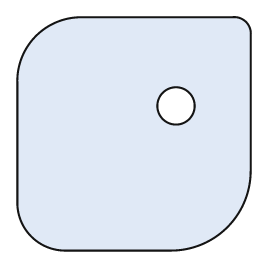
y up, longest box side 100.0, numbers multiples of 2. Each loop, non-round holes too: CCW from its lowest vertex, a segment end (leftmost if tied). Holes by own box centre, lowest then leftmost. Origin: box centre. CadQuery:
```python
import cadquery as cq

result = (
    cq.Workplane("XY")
    .moveTo(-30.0, -50.0)
    .lineTo(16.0, -50.0)
    .threePointArc((40.0, -40.0), (50.0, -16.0))
    .lineTo(50.0, 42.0)
    .threePointArc((48.0, 48.0), (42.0, 50.0))
    .lineTo(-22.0, 50.0)
    .threePointArc((-42.0, 42.0), (-50.0, 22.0))
    .lineTo(-50.0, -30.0)
    .threePointArc((-44.0, -44.0), (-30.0, -50.0))
    .close()
    .moveTo(18.0, 12.0)
    .circle(8.0)
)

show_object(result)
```